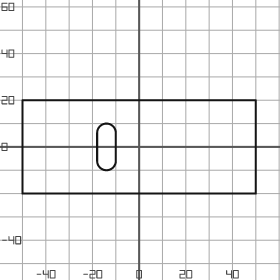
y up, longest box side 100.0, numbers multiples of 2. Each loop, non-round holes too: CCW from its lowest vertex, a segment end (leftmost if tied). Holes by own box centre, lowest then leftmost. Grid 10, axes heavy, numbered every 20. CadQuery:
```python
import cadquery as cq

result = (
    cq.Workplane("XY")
    .moveTo(-50.0, -20.0)
    .lineTo(50.0, -20.0)
    .lineTo(50.0, 20.0)
    .lineTo(-50.0, 20.0)
    .close()
    .moveTo(-18.0, -6.0)
    .threePointArc((-14.0, -10.0), (-10.0, -6.0))
    .lineTo(-10.0, 6.0)
    .threePointArc((-14.0, 10.0), (-18.0, 6.0))
    .close()
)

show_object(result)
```